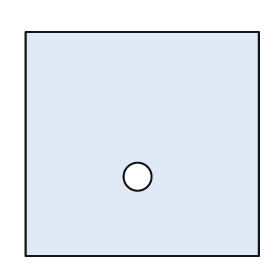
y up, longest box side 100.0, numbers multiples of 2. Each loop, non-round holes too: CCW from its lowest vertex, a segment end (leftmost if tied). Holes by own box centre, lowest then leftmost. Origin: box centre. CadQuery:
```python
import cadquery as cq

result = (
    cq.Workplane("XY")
    .moveTo(-50.0, -48.0)
    .lineTo(50.0, -48.0)
    .lineTo(50.0, 48.0)
    .lineTo(-50.0, 48.0)
    .close()
    .moveTo(-2.0, -14.0)
    .circle(6.0)
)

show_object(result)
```